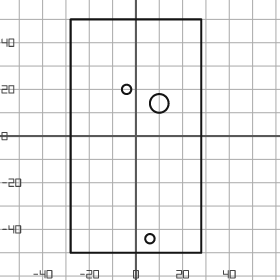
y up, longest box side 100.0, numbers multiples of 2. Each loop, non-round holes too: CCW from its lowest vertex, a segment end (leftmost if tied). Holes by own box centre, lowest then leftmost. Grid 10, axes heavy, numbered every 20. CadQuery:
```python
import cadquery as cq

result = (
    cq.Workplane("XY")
    .moveTo(-28.0, -50.0)
    .lineTo(28.0, -50.0)
    .lineTo(28.0, 50.0)
    .lineTo(-28.0, 50.0)
    .close()
    .moveTo(6.0, -44.0)
    .circle(2.0)
    .moveTo(10.0, 14.0)
    .circle(4.0)
    .moveTo(-4.0, 20.0)
    .circle(2.0)
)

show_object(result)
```